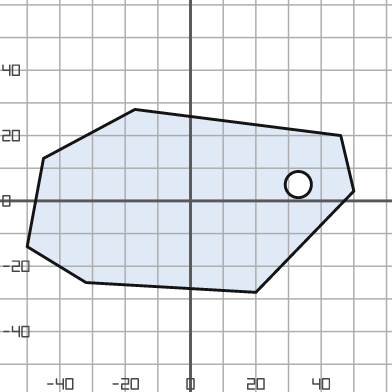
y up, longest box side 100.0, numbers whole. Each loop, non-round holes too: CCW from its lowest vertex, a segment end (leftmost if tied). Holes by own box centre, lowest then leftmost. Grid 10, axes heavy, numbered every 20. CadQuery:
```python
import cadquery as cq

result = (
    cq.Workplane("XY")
    .moveTo(20.0, -28.0)
    .lineTo(50.0, 3.0)
    .lineTo(46.0, 20.0)
    .lineTo(-17.0, 28.0)
    .lineTo(-45.0, 13.0)
    .lineTo(-50.0, -14.0)
    .lineTo(-32.0, -25.0)
    .close()
    .moveTo(33.0, 5.0)
    .circle(4.0)
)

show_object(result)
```